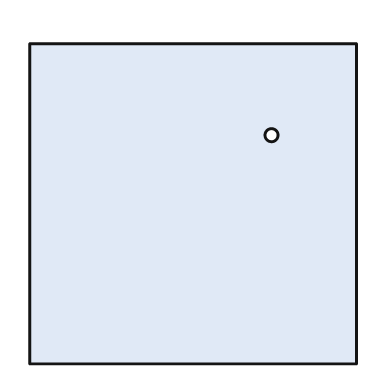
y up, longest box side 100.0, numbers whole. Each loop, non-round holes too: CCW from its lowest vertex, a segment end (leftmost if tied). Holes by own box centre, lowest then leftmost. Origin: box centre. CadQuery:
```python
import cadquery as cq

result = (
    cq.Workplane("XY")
    .moveTo(-50.0, -49.0)
    .lineTo(50.0, -49.0)
    .lineTo(50.0, 49.0)
    .lineTo(-50.0, 49.0)
    .close()
    .moveTo(24.0, 21.0)
    .circle(2.0)
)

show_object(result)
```